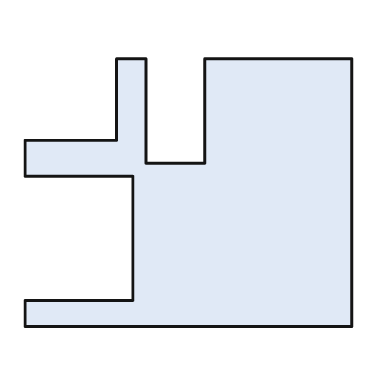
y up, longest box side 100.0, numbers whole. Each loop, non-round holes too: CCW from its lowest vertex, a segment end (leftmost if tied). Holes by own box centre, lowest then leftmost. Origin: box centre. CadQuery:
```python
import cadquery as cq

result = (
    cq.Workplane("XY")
    .moveTo(-50.0, -41.0)
    .lineTo(50.0, -41.0)
    .lineTo(50.0, 41.0)
    .lineTo(5.0, 41.0)
    .lineTo(5.0, 9.0)
    .lineTo(-13.0, 9.0)
    .lineTo(-13.0, 41.0)
    .lineTo(-22.0, 41.0)
    .lineTo(-22.0, 16.0)
    .lineTo(-50.0, 16.0)
    .lineTo(-50.0, 5.0)
    .lineTo(-17.0, 5.0)
    .lineTo(-17.0, -33.0)
    .lineTo(-50.0, -33.0)
    .close()
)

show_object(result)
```